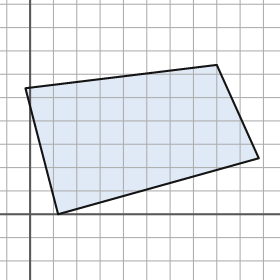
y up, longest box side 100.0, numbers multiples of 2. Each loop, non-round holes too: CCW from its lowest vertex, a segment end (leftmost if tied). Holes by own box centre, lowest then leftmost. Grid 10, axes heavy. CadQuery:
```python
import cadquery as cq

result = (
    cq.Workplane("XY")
    .moveTo(12.0, 0.0)
    .lineTo(98.0, 24.0)
    .lineTo(80.0, 64.0)
    .lineTo(-2.0, 54.0)
    .close()
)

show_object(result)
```